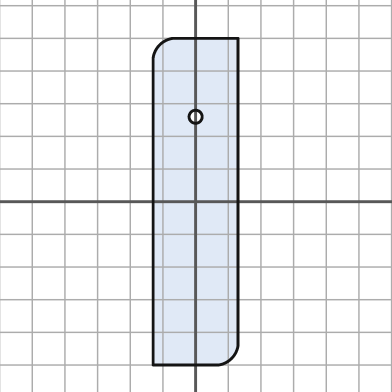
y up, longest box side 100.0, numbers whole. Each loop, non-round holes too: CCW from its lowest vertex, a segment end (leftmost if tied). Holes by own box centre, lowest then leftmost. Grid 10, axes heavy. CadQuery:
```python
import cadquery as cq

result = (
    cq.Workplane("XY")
    .moveTo(-13.0, -50.0)
    .lineTo(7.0, -50.0)
    .threePointArc((11.0, -48.0), (13.0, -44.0))
    .lineTo(13.0, 50.0)
    .lineTo(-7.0, 50.0)
    .threePointArc((-11.0, 48.0), (-13.0, 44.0))
    .close()
    .moveTo(0.0, 26.0)
    .circle(2.0)
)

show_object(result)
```